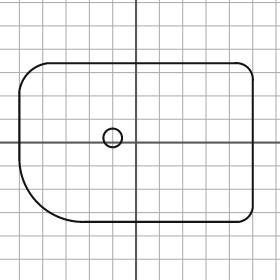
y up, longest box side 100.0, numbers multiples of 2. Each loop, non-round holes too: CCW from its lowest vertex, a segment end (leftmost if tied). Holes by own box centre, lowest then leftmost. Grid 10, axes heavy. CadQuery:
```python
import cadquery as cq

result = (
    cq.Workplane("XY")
    .moveTo(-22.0, -34.0)
    .lineTo(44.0, -34.0)
    .threePointArc((48.0, -32.0), (50.0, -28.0))
    .lineTo(50.0, 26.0)
    .threePointArc((48.0, 32.0), (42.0, 34.0))
    .lineTo(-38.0, 34.0)
    .threePointArc((-46.0, 30.0), (-50.0, 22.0))
    .lineTo(-50.0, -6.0)
    .threePointArc((-42.0, -26.0), (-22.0, -34.0))
    .close()
    .moveTo(-10.0, 2.0)
    .circle(4.0)
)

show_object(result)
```